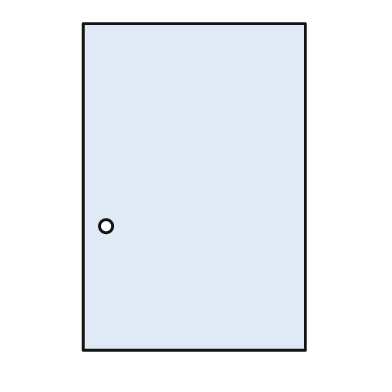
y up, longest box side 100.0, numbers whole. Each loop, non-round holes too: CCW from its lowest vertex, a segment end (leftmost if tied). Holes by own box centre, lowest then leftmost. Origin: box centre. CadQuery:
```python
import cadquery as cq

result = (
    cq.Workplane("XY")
    .moveTo(-34.0, -50.0)
    .lineTo(34.0, -50.0)
    .lineTo(34.0, 50.0)
    .lineTo(-34.0, 50.0)
    .close()
    .moveTo(-27.0, -12.0)
    .circle(2.0)
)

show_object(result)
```